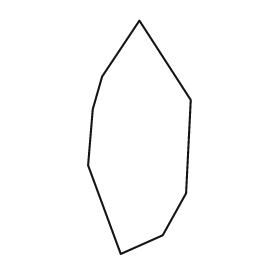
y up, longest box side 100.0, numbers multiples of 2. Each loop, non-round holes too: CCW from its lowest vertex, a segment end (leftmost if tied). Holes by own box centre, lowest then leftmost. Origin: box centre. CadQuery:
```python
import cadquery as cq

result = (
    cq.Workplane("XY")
    .moveTo(-8.0, -50.0)
    .lineTo(10.0, -42.0)
    .lineTo(20.0, -24.0)
    .lineTo(22.0, 16.0)
    .lineTo(0.0, 50.0)
    .lineTo(-16.0, 26.0)
    .lineTo(-20.0, 12.0)
    .lineTo(-22.0, -12.0)
    .close()
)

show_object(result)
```